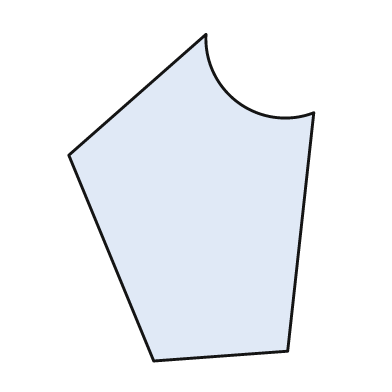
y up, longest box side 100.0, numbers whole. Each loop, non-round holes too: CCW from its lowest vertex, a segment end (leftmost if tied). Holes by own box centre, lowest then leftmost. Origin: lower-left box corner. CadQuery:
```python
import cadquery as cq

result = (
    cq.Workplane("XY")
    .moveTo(26.0, 0.0)
    .lineTo(67.0, 3.0)
    .lineTo(75.0, 76.0)
    .threePointArc((52.0, 79.0), (42.0, 100.0))
    .lineTo(0.0, 63.0)
    .close()
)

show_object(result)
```